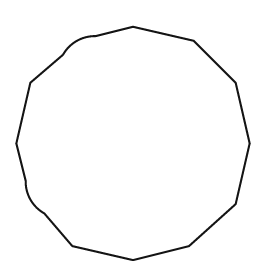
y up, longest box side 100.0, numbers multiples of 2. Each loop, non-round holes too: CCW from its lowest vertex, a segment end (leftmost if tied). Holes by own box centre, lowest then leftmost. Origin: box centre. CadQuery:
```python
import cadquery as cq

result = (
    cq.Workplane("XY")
    .moveTo(0.0, -50.0)
    .lineTo(24.0, -44.0)
    .lineTo(44.0, -26.0)
    .lineTo(50.0, 0.0)
    .lineTo(44.0, 26.0)
    .lineTo(26.0, 44.0)
    .lineTo(0.0, 50.0)
    .lineTo(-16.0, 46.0)
    .threePointArc((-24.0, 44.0), (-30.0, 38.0))
    .lineTo(-44.0, 26.0)
    .lineTo(-50.0, 0.0)
    .lineTo(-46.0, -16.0)
    .threePointArc((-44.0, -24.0), (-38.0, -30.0))
    .lineTo(-26.0, -44.0)
    .close()
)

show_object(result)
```